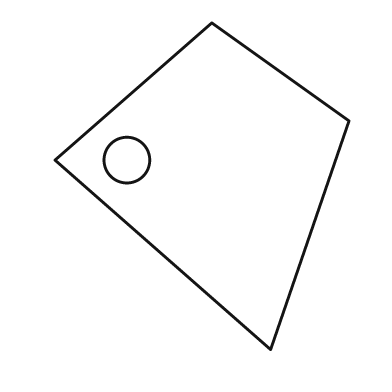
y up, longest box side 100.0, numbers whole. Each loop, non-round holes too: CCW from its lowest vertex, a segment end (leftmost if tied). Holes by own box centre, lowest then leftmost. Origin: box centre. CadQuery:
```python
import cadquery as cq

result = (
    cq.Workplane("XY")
    .moveTo(21.0, -50.0)
    .lineTo(45.0, 20.0)
    .lineTo(3.0, 50.0)
    .lineTo(-45.0, 8.0)
    .close()
    .moveTo(-23.0, 8.0)
    .circle(7.0)
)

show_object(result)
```